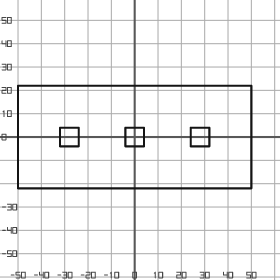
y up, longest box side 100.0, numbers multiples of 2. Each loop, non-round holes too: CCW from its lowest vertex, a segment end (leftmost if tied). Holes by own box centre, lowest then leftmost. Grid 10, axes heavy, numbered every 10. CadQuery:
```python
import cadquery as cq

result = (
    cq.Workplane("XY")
    .moveTo(-50.0, -22.0)
    .lineTo(50.0, -22.0)
    .lineTo(50.0, 22.0)
    .lineTo(-50.0, 22.0)
    .close()
    .moveTo(-32.0, -4.0)
    .lineTo(-24.0, -4.0)
    .lineTo(-24.0, 4.0)
    .lineTo(-32.0, 4.0)
    .close()
    .moveTo(-4.0, -4.0)
    .lineTo(4.0, -4.0)
    .lineTo(4.0, 4.0)
    .lineTo(-4.0, 4.0)
    .close()
    .moveTo(24.0, -4.0)
    .lineTo(32.0, -4.0)
    .lineTo(32.0, 4.0)
    .lineTo(24.0, 4.0)
    .close()
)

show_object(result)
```